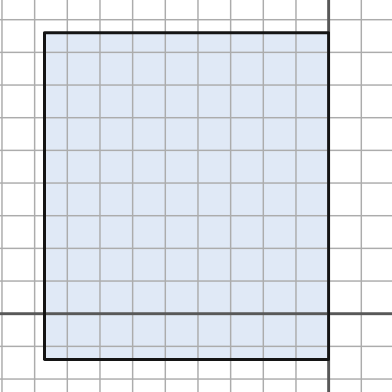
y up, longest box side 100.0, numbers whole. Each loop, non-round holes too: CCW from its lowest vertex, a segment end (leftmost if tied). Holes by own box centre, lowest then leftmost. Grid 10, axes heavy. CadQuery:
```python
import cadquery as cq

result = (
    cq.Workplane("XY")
    .moveTo(-87.0, -14.0)
    .lineTo(0.0, -14.0)
    .lineTo(0.0, 86.0)
    .lineTo(-87.0, 86.0)
    .close()
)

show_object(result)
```